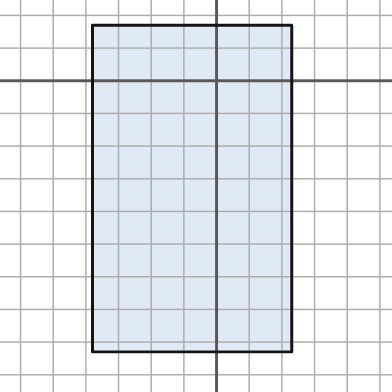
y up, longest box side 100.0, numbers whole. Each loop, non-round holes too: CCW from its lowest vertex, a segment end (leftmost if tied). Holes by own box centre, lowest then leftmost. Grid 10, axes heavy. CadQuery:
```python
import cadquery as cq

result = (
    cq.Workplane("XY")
    .moveTo(-38.0, -83.0)
    .lineTo(23.0, -83.0)
    .lineTo(23.0, 17.0)
    .lineTo(-38.0, 17.0)
    .close()
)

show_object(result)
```